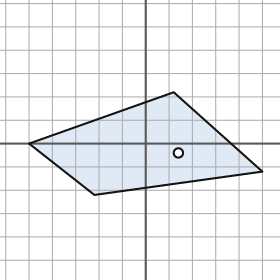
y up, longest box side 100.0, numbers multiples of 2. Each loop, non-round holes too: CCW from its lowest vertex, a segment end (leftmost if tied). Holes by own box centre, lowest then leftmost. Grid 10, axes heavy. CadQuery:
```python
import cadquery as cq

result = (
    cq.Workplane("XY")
    .moveTo(-22.0, -22.0)
    .lineTo(50.0, -12.0)
    .lineTo(12.0, 22.0)
    .lineTo(-50.0, 0.0)
    .close()
    .moveTo(14.0, -4.0)
    .circle(2.0)
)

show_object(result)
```